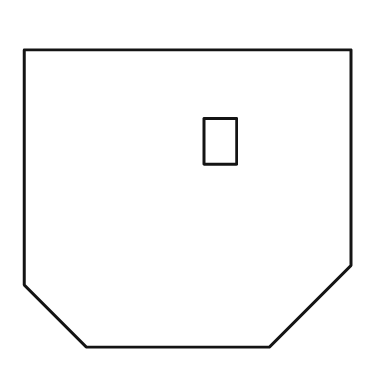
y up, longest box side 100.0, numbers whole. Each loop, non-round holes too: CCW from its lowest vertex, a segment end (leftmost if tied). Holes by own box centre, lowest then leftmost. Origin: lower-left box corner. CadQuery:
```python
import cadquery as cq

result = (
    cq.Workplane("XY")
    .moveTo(19.0, 0.0)
    .lineTo(75.0, 0.0)
    .lineTo(100.0, 25.0)
    .lineTo(100.0, 91.0)
    .lineTo(0.0, 91.0)
    .lineTo(0.0, 19.0)
    .close()
    .moveTo(55.0, 56.0)
    .lineTo(65.0, 56.0)
    .lineTo(65.0, 70.0)
    .lineTo(55.0, 70.0)
    .close()
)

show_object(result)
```